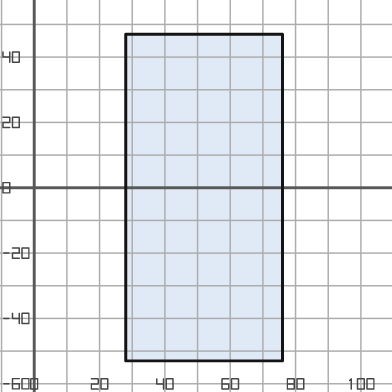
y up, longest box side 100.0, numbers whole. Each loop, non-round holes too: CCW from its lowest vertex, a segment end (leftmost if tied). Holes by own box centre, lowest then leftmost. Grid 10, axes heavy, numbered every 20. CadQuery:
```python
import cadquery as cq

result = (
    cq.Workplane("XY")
    .moveTo(28.0, -53.0)
    .lineTo(76.0, -53.0)
    .lineTo(76.0, 47.0)
    .lineTo(28.0, 47.0)
    .close()
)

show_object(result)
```